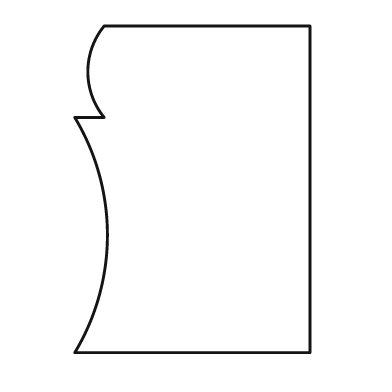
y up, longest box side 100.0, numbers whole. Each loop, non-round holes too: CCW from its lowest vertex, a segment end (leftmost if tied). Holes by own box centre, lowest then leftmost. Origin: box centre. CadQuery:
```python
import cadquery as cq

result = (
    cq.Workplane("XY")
    .moveTo(-36.0, -50.0)
    .lineTo(36.0, -50.0)
    .lineTo(36.0, 50.0)
    .lineTo(-27.0, 50.0)
    .threePointArc((-32.0, 36.0), (-27.0, 22.0))
    .lineTo(-36.0, 22.0)
    .threePointArc((-26.0, -14.0), (-36.0, -50.0))
    .close()
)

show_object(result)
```